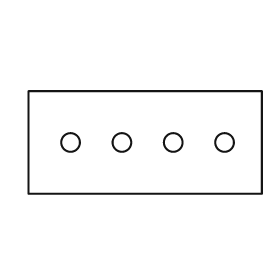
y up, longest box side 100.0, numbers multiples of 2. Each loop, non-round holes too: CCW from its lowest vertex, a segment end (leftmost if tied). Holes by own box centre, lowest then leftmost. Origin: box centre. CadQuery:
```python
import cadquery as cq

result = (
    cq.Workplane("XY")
    .moveTo(-50.0, -22.0)
    .lineTo(50.0, -22.0)
    .lineTo(50.0, 22.0)
    .lineTo(-50.0, 22.0)
    .close()
    .moveTo(-32.0, 0.0)
    .circle(4.0)
    .moveTo(-10.0, 0.0)
    .circle(4.0)
    .moveTo(12.0, 0.0)
    .circle(4.0)
    .moveTo(34.0, 0.0)
    .circle(4.0)
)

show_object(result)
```